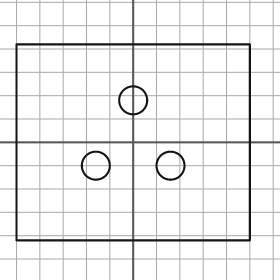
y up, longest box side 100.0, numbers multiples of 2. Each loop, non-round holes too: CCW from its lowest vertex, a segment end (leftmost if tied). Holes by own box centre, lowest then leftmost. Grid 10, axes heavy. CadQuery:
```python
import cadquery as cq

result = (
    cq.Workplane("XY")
    .moveTo(-50.0, -42.0)
    .lineTo(50.0, -42.0)
    .lineTo(50.0, 42.0)
    .lineTo(-50.0, 42.0)
    .close()
    .moveTo(-16.0, -10.0)
    .circle(6.0)
    .moveTo(16.0, -10.0)
    .circle(6.0)
    .moveTo(0.0, 18.0)
    .circle(6.0)
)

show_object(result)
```